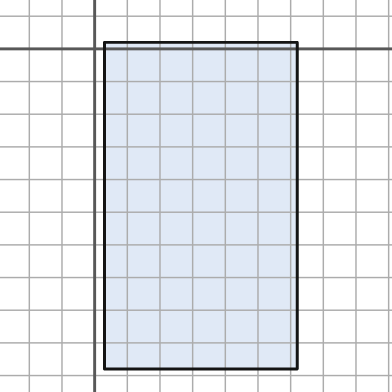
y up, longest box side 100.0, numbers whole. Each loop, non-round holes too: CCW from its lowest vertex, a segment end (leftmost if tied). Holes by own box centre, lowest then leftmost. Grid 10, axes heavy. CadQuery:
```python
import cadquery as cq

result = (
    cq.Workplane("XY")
    .moveTo(3.0, -98.0)
    .lineTo(62.0, -98.0)
    .lineTo(62.0, 2.0)
    .lineTo(3.0, 2.0)
    .close()
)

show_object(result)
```